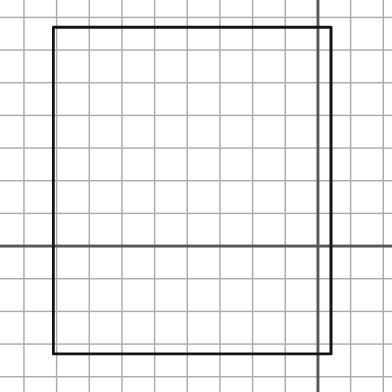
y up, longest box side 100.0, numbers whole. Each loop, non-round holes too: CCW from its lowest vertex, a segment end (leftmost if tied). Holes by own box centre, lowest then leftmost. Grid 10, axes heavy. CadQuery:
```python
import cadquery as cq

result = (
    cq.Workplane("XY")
    .moveTo(-81.0, -33.0)
    .lineTo(4.0, -33.0)
    .lineTo(4.0, 67.0)
    .lineTo(-81.0, 67.0)
    .close()
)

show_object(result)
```